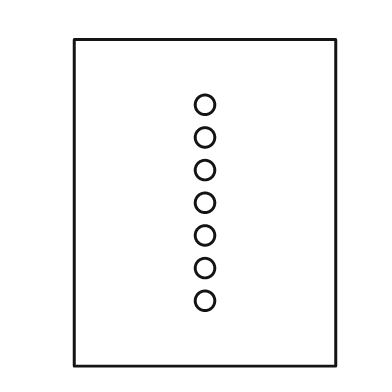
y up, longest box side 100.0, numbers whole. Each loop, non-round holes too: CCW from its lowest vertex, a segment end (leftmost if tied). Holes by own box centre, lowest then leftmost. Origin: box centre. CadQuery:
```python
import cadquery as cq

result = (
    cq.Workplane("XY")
    .moveTo(-40.0, -50.0)
    .lineTo(40.0, -50.0)
    .lineTo(40.0, 50.0)
    .lineTo(-40.0, 50.0)
    .close()
    .moveTo(0.0, -30.0)
    .circle(3.0)
    .moveTo(0.0, -20.0)
    .circle(3.0)
    .moveTo(0.0, -10.0)
    .circle(3.0)
    .moveTo(0.0, 0.0)
    .circle(3.0)
    .moveTo(0.0, 10.0)
    .circle(3.0)
    .moveTo(0.0, 20.0)
    .circle(3.0)
    .moveTo(0.0, 30.0)
    .circle(3.0)
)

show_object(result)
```